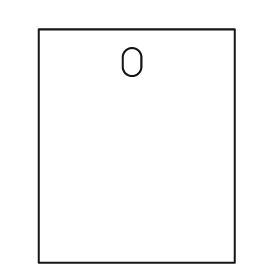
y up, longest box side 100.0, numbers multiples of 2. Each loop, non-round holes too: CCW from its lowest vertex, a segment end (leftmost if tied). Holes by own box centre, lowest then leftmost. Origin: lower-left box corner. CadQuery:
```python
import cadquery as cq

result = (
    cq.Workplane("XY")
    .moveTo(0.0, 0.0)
    .lineTo(84.0, 0.0)
    .lineTo(84.0, 100.0)
    .lineTo(0.0, 100.0)
    .close()
    .moveTo(36.0, 84.0)
    .threePointArc((40.0, 80.0), (44.0, 84.0))
    .lineTo(44.0, 88.0)
    .threePointArc((40.0, 92.0), (36.0, 88.0))
    .close()
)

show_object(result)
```